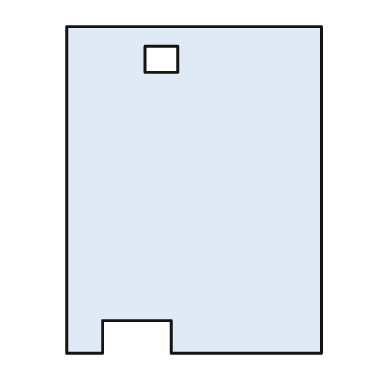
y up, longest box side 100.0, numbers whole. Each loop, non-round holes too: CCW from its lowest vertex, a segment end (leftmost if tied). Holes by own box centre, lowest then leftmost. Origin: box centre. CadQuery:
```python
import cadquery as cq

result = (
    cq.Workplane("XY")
    .moveTo(-39.0, -50.0)
    .lineTo(-28.0, -50.0)
    .lineTo(-28.0, -40.0)
    .lineTo(-7.0, -40.0)
    .lineTo(-7.0, -50.0)
    .lineTo(39.0, -50.0)
    .lineTo(39.0, 50.0)
    .lineTo(-39.0, 50.0)
    .close()
    .moveTo(-15.0, 36.0)
    .lineTo(-5.0, 36.0)
    .lineTo(-5.0, 44.0)
    .lineTo(-15.0, 44.0)
    .close()
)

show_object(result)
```